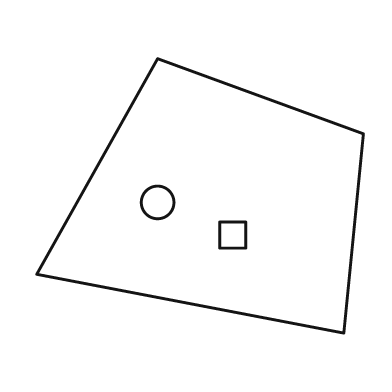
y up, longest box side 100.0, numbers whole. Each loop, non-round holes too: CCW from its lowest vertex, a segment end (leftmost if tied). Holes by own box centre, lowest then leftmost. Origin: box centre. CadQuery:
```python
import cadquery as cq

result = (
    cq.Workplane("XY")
    .moveTo(44.0, -42.0)
    .lineTo(50.0, 19.0)
    .lineTo(-13.0, 42.0)
    .lineTo(-50.0, -24.0)
    .close()
    .moveTo(6.0, -16.0)
    .lineTo(14.0, -16.0)
    .lineTo(14.0, -8.0)
    .lineTo(6.0, -8.0)
    .close()
    .moveTo(-13.0, -2.0)
    .circle(5.0)
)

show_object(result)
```